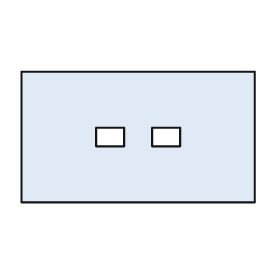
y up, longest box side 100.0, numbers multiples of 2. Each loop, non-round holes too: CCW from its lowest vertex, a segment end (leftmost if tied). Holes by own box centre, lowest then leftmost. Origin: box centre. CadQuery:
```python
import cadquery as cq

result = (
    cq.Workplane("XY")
    .moveTo(-50.0, -28.0)
    .lineTo(50.0, -28.0)
    .lineTo(50.0, 28.0)
    .lineTo(-50.0, 28.0)
    .close()
    .moveTo(-18.0, -4.0)
    .lineTo(-6.0, -4.0)
    .lineTo(-6.0, 4.0)
    .lineTo(-18.0, 4.0)
    .close()
    .moveTo(6.0, -4.0)
    .lineTo(18.0, -4.0)
    .lineTo(18.0, 4.0)
    .lineTo(6.0, 4.0)
    .close()
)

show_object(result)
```